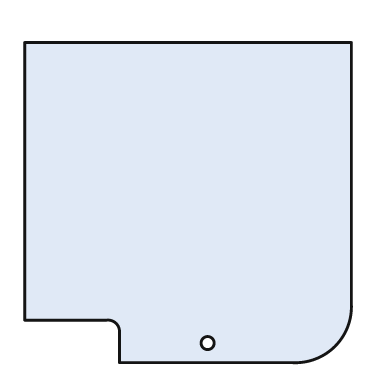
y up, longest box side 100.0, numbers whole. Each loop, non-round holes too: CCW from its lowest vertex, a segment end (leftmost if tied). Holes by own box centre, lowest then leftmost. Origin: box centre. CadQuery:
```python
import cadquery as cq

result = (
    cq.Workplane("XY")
    .moveTo(-21.0, -49.0)
    .lineTo(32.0, -49.0)
    .threePointArc((45.0, -44.0), (50.0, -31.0))
    .lineTo(50.0, 49.0)
    .lineTo(-50.0, 49.0)
    .lineTo(-50.0, -36.0)
    .lineTo(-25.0, -36.0)
    .threePointArc((-22.0, -37.0), (-21.0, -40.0))
    .close()
    .moveTo(6.0, -43.0)
    .circle(2.0)
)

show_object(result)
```